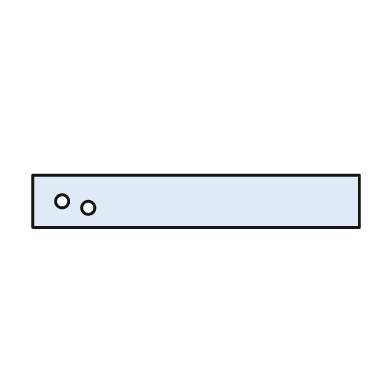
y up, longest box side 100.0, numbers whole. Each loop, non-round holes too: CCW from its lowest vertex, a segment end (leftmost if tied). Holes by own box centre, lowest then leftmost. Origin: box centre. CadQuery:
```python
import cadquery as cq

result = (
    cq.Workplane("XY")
    .moveTo(-50.0, -8.0)
    .lineTo(50.0, -8.0)
    .lineTo(50.0, 8.0)
    .lineTo(-50.0, 8.0)
    .close()
    .moveTo(-33.0, -2.0)
    .circle(2.0)
    .moveTo(-41.0, 0.0)
    .circle(2.0)
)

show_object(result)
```